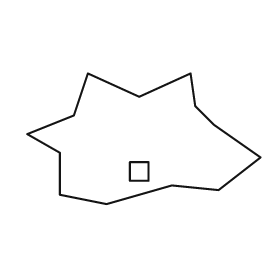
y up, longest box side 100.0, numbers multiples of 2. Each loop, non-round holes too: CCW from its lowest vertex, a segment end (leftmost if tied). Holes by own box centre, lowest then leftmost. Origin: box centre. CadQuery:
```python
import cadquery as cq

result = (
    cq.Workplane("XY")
    .moveTo(-16.0, -28.0)
    .lineTo(12.0, -20.0)
    .lineTo(32.0, -22.0)
    .lineTo(50.0, -8.0)
    .lineTo(30.0, 6.0)
    .lineTo(22.0, 14.0)
    .lineTo(20.0, 28.0)
    .lineTo(-2.0, 18.0)
    .lineTo(-24.0, 28.0)
    .lineTo(-30.0, 10.0)
    .lineTo(-50.0, 2.0)
    .lineTo(-36.0, -6.0)
    .lineTo(-36.0, -24.0)
    .close()
    .moveTo(-6.0, -18.0)
    .lineTo(2.0, -18.0)
    .lineTo(2.0, -10.0)
    .lineTo(-6.0, -10.0)
    .close()
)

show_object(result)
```